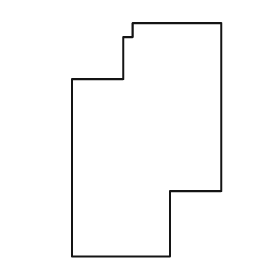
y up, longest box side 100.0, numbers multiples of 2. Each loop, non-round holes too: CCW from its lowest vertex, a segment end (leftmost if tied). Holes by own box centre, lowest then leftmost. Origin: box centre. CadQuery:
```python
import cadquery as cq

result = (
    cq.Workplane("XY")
    .moveTo(-32.0, -50.0)
    .lineTo(10.0, -50.0)
    .lineTo(10.0, -22.0)
    .lineTo(32.0, -22.0)
    .lineTo(32.0, 50.0)
    .lineTo(-6.0, 50.0)
    .lineTo(-6.0, 44.0)
    .lineTo(-10.0, 44.0)
    .lineTo(-10.0, 26.0)
    .lineTo(-32.0, 26.0)
    .close()
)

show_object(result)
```